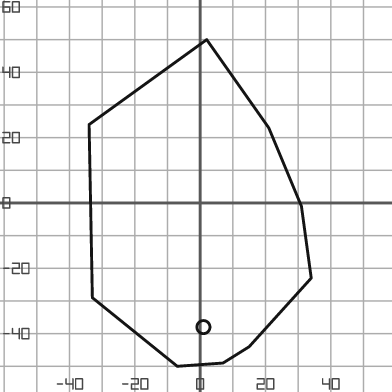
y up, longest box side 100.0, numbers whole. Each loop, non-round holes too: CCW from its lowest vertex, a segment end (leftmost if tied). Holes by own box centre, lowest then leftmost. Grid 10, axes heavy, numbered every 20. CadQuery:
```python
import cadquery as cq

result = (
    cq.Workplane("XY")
    .moveTo(-7.0, -50.0)
    .lineTo(7.0, -49.0)
    .lineTo(15.0, -44.0)
    .lineTo(34.0, -23.0)
    .lineTo(31.0, -1.0)
    .lineTo(21.0, 23.0)
    .lineTo(2.0, 50.0)
    .lineTo(-34.0, 24.0)
    .lineTo(-33.0, -29.0)
    .close()
    .moveTo(1.0, -38.0)
    .circle(2.0)
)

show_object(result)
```